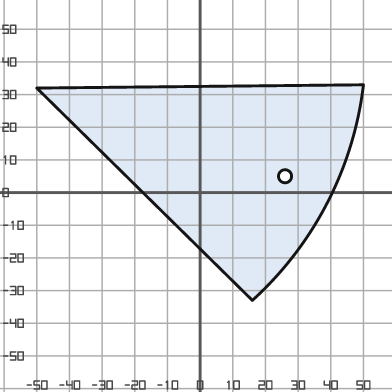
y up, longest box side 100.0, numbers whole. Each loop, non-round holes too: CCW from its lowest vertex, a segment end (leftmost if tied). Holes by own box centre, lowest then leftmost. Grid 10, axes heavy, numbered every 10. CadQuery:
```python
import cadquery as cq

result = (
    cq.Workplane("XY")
    .moveTo(16.0, -33.0)
    .threePointArc((39.0, -3.0), (50.0, 33.0))
    .lineTo(-50.0, 32.0)
    .close()
    .moveTo(26.0, 5.0)
    .circle(2.0)
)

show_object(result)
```